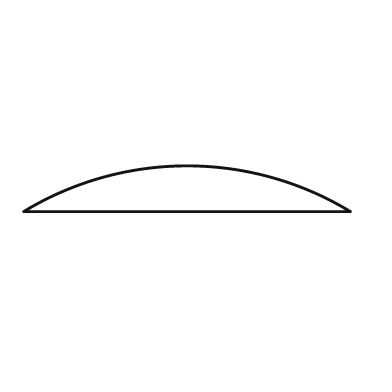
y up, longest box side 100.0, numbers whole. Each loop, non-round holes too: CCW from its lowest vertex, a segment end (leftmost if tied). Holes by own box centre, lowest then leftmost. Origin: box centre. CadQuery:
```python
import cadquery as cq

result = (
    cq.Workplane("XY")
    .moveTo(-50.0, -7.0)
    .lineTo(50.0, -7.0)
    .threePointArc((0.0, 7.0), (-50.0, -7.0))
    .close()
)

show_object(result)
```